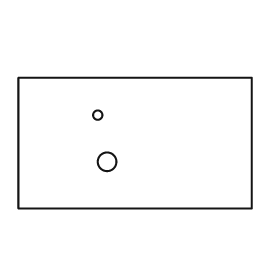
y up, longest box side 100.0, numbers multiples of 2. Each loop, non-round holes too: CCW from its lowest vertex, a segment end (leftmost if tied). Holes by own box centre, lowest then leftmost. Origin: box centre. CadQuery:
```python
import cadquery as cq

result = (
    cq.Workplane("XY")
    .moveTo(-50.0, -28.0)
    .lineTo(50.0, -28.0)
    .lineTo(50.0, 28.0)
    .lineTo(-50.0, 28.0)
    .close()
    .moveTo(-12.0, -8.0)
    .circle(4.0)
    .moveTo(-16.0, 12.0)
    .circle(2.0)
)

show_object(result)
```